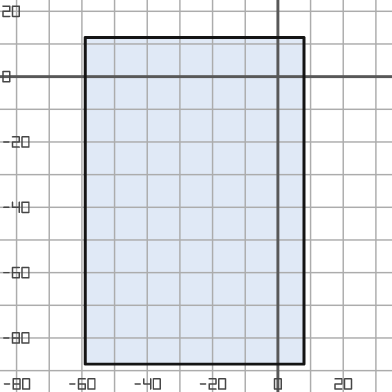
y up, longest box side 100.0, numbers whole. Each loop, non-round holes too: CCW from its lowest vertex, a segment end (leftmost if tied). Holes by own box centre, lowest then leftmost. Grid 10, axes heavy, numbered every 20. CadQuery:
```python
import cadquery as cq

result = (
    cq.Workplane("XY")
    .moveTo(-59.0, -88.0)
    .lineTo(8.0, -88.0)
    .lineTo(8.0, 12.0)
    .lineTo(-59.0, 12.0)
    .close()
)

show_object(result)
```